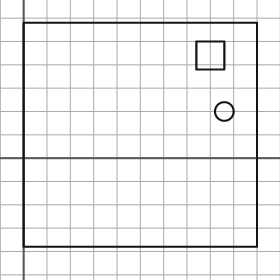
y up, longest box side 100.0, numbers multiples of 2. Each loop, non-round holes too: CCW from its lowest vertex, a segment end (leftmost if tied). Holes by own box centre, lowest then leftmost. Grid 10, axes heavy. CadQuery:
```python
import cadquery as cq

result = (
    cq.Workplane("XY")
    .moveTo(0.0, -38.0)
    .lineTo(100.0, -38.0)
    .lineTo(100.0, 58.0)
    .lineTo(0.0, 58.0)
    .close()
    .moveTo(86.0, 20.0)
    .circle(4.0)
    .moveTo(74.0, 38.0)
    .lineTo(86.0, 38.0)
    .lineTo(86.0, 50.0)
    .lineTo(74.0, 50.0)
    .close()
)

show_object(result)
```